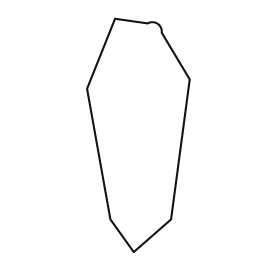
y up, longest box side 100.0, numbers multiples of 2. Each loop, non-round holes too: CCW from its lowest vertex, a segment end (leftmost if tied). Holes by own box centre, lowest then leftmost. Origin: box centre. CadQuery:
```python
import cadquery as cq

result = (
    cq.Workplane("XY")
    .moveTo(-2.0, -50.0)
    .lineTo(14.0, -36.0)
    .lineTo(22.0, 24.0)
    .lineTo(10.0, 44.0)
    .threePointArc((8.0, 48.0), (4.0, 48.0))
    .lineTo(-10.0, 50.0)
    .lineTo(-22.0, 20.0)
    .lineTo(-12.0, -36.0)
    .close()
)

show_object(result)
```